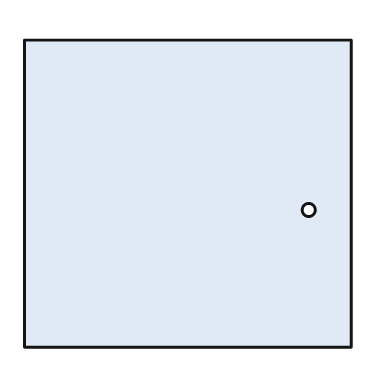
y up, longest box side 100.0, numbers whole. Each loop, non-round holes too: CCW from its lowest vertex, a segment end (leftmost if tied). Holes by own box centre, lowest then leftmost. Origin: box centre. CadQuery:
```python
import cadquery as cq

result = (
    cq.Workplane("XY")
    .moveTo(-50.0, -47.0)
    .lineTo(50.0, -47.0)
    .lineTo(50.0, 47.0)
    .lineTo(-50.0, 47.0)
    .close()
    .moveTo(37.0, -5.0)
    .circle(2.0)
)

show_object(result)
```